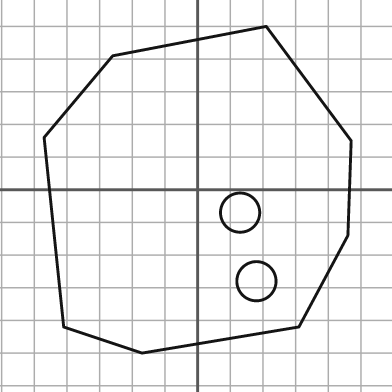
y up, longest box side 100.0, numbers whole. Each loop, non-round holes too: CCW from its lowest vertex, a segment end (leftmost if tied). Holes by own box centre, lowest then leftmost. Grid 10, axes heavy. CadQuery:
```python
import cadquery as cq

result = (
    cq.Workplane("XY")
    .moveTo(-17.0, -50.0)
    .lineTo(31.0, -42.0)
    .lineTo(46.0, -14.0)
    .lineTo(47.0, 15.0)
    .lineTo(21.0, 50.0)
    .lineTo(-26.0, 41.0)
    .lineTo(-47.0, 16.0)
    .lineTo(-41.0, -42.0)
    .close()
    .moveTo(18.0, -28.0)
    .circle(6.0)
    .moveTo(13.0, -7.0)
    .circle(6.0)
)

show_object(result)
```